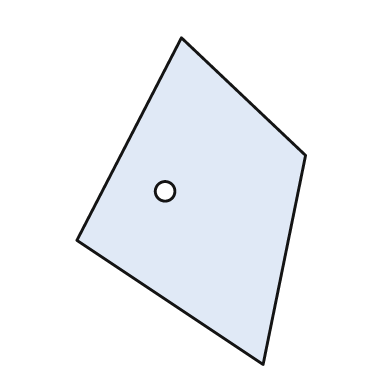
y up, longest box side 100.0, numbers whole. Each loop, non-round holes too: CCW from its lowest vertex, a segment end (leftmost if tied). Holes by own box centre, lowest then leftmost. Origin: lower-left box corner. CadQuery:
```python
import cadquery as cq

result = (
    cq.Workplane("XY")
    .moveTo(57.0, 0.0)
    .lineTo(70.0, 64.0)
    .lineTo(32.0, 100.0)
    .lineTo(0.0, 38.0)
    .close()
    .moveTo(27.0, 53.0)
    .circle(3.0)
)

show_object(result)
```